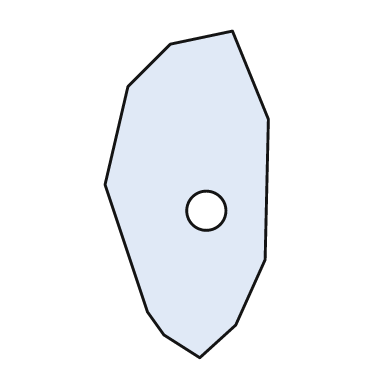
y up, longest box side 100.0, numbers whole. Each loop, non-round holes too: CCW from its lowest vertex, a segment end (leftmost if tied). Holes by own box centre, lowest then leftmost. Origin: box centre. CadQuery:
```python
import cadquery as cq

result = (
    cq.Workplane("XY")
    .moveTo(4.0, -50.0)
    .lineTo(15.0, -40.0)
    .lineTo(24.0, -20.0)
    .lineTo(25.0, 23.0)
    .lineTo(14.0, 50.0)
    .lineTo(-5.0, 46.0)
    .lineTo(-18.0, 33.0)
    .lineTo(-25.0, 3.0)
    .lineTo(-12.0, -36.0)
    .lineTo(-7.0, -43.0)
    .close()
    .moveTo(6.0, -5.0)
    .circle(6.0)
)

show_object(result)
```